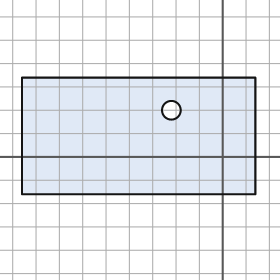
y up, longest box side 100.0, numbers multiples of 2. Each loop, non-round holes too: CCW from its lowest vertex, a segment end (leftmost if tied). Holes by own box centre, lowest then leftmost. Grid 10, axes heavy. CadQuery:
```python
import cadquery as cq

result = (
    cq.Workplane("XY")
    .moveTo(-86.0, -16.0)
    .lineTo(14.0, -16.0)
    .lineTo(14.0, 34.0)
    .lineTo(-86.0, 34.0)
    .close()
    .moveTo(-22.0, 20.0)
    .circle(4.0)
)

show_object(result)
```